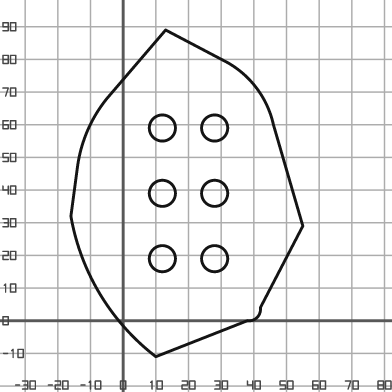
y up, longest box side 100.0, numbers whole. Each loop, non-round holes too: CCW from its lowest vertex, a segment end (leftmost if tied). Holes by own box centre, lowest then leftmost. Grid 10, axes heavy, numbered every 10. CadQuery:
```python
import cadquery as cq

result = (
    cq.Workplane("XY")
    .moveTo(10.0, -11.0)
    .lineTo(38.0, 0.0)
    .threePointArc((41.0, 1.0), (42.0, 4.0))
    .lineTo(55.0, 29.0)
    .lineTo(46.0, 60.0)
    .threePointArc((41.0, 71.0), (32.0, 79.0))
    .lineTo(13.0, 89.0)
    .lineTo(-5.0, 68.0)
    .threePointArc((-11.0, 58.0), (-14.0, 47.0))
    .lineTo(-16.0, 32.0)
    .threePointArc((-7.0, 8.0), (10.0, -11.0))
    .close()
    .moveTo(12.0, 19.0)
    .circle(4.0)
    .moveTo(28.0, 19.0)
    .circle(4.0)
    .moveTo(12.0, 39.0)
    .circle(4.0)
    .moveTo(28.0, 39.0)
    .circle(4.0)
    .moveTo(12.0, 59.0)
    .circle(4.0)
    .moveTo(28.0, 59.0)
    .circle(4.0)
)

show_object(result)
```